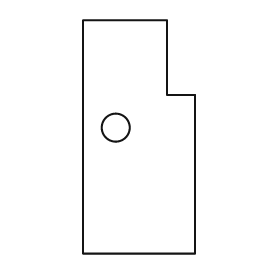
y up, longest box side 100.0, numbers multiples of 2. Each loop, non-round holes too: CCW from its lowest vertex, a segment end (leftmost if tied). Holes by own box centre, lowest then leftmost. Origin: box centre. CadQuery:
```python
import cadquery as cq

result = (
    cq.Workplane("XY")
    .moveTo(-24.0, -50.0)
    .lineTo(24.0, -50.0)
    .lineTo(24.0, 18.0)
    .lineTo(12.0, 18.0)
    .lineTo(12.0, 50.0)
    .lineTo(-24.0, 50.0)
    .close()
    .moveTo(-10.0, 4.0)
    .circle(6.0)
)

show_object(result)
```